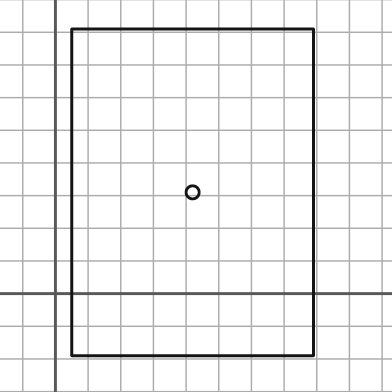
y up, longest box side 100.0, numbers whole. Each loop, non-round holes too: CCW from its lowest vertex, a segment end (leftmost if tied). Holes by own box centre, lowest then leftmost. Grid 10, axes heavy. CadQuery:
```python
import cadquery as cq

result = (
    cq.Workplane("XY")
    .moveTo(5.0, -19.0)
    .lineTo(79.0, -19.0)
    .lineTo(79.0, 81.0)
    .lineTo(5.0, 81.0)
    .close()
    .moveTo(42.0, 31.0)
    .circle(2.0)
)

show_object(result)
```